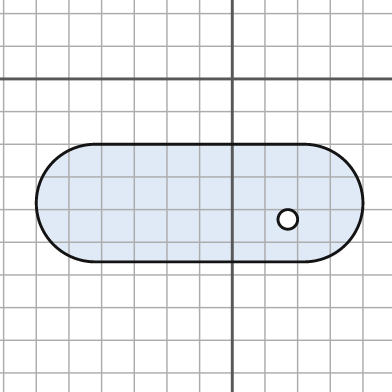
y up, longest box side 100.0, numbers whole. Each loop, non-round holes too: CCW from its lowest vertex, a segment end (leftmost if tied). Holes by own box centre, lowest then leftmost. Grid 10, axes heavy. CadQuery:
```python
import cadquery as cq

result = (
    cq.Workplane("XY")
    .moveTo(-42.0, -56.0)
    .lineTo(22.0, -56.0)
    .threePointArc((40.0, -38.0), (22.0, -20.0))
    .lineTo(-42.0, -20.0)
    .threePointArc((-60.0, -38.0), (-42.0, -56.0))
    .close()
    .moveTo(17.0, -43.0)
    .circle(3.0)
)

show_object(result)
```